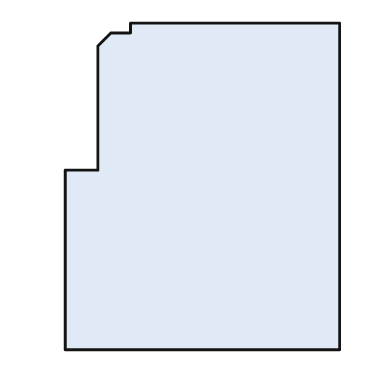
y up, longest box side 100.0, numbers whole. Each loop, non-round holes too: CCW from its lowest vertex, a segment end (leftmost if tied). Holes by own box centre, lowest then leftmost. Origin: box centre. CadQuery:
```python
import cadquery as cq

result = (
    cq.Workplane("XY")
    .moveTo(-42.0, -50.0)
    .lineTo(42.0, -50.0)
    .lineTo(42.0, 50.0)
    .lineTo(-22.0, 50.0)
    .lineTo(-22.0, 47.0)
    .lineTo(-28.0, 47.0)
    .lineTo(-32.0, 43.0)
    .lineTo(-32.0, 5.0)
    .lineTo(-42.0, 5.0)
    .close()
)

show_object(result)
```